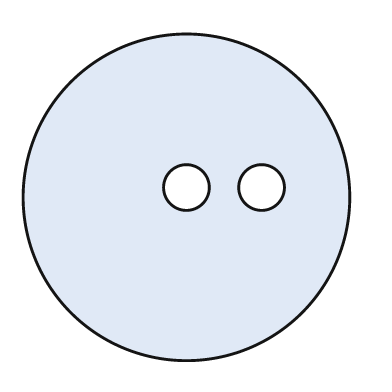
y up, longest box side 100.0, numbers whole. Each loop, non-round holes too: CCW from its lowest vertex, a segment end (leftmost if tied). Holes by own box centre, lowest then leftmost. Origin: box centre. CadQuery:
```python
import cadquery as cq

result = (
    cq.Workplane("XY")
    .moveTo(0.0, 0.0)
    .circle(50.0)
    .moveTo(0.0, 3.0)
    .circle(7.0)
    .moveTo(23.0, 3.0)
    .circle(7.0)
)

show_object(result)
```